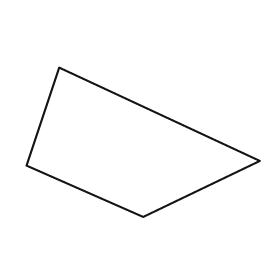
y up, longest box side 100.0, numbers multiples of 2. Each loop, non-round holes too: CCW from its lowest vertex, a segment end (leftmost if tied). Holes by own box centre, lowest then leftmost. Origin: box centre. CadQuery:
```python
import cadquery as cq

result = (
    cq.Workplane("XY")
    .moveTo(0.0, -32.0)
    .lineTo(50.0, -8.0)
    .lineTo(-36.0, 32.0)
    .lineTo(-50.0, -10.0)
    .close()
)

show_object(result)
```